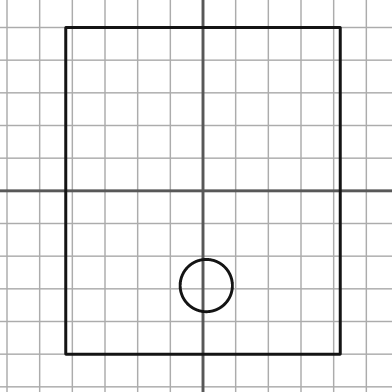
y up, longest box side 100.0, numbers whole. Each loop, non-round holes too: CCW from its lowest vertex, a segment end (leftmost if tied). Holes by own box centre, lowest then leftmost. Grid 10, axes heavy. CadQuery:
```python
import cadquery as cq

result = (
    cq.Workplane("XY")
    .moveTo(-42.0, -50.0)
    .lineTo(42.0, -50.0)
    .lineTo(42.0, 50.0)
    .lineTo(-42.0, 50.0)
    .close()
    .moveTo(1.0, -29.0)
    .circle(8.0)
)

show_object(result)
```